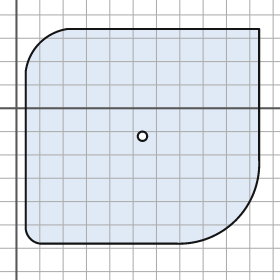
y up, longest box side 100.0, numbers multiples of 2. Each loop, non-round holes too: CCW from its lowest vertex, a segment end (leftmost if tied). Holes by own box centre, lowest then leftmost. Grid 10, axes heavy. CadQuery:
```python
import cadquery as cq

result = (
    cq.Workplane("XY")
    .moveTo(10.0, -58.0)
    .lineTo(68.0, -58.0)
    .threePointArc((94.0, -48.0), (104.0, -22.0))
    .lineTo(104.0, 34.0)
    .lineTo(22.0, 34.0)
    .threePointArc((10.0, 28.0), (4.0, 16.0))
    .lineTo(4.0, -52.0)
    .threePointArc((6.0, -56.0), (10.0, -58.0))
    .close()
    .moveTo(54.0, -12.0)
    .circle(2.0)
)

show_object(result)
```